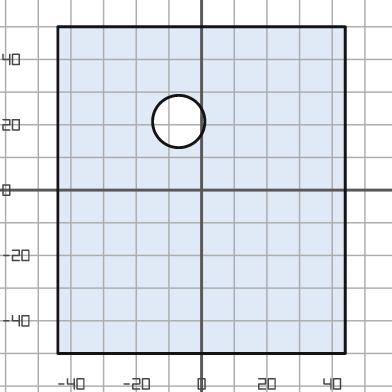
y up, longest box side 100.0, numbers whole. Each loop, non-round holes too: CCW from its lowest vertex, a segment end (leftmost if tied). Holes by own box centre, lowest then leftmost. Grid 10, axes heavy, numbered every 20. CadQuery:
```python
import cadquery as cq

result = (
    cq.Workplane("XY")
    .moveTo(-44.0, -50.0)
    .lineTo(44.0, -50.0)
    .lineTo(44.0, 50.0)
    .lineTo(-44.0, 50.0)
    .close()
    .moveTo(-7.0, 21.0)
    .circle(8.0)
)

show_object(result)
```